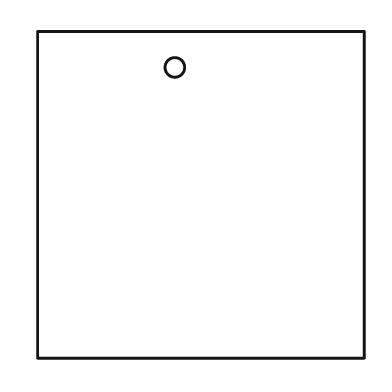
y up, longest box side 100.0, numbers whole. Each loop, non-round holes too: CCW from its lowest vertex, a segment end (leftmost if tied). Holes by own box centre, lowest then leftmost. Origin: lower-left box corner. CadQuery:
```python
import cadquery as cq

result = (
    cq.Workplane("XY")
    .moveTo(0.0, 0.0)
    .lineTo(100.0, 0.0)
    .lineTo(100.0, 100.0)
    .lineTo(0.0, 100.0)
    .close()
    .moveTo(42.0, 89.0)
    .circle(3.0)
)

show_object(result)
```